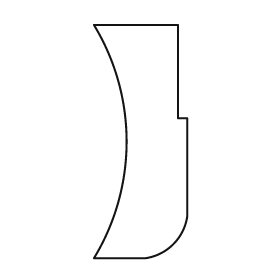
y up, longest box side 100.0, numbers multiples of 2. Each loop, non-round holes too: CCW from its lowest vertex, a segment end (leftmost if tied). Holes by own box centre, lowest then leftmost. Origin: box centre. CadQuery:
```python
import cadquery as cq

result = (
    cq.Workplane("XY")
    .moveTo(-20.0, -50.0)
    .lineTo(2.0, -50.0)
    .threePointArc((14.0, -44.0), (20.0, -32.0))
    .lineTo(20.0, 10.0)
    .lineTo(16.0, 10.0)
    .lineTo(16.0, 50.0)
    .lineTo(-20.0, 50.0)
    .threePointArc((-6.0, 0.0), (-20.0, -50.0))
    .close()
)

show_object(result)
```